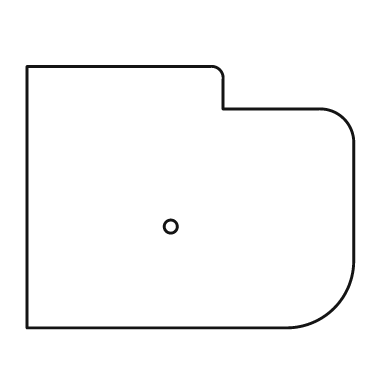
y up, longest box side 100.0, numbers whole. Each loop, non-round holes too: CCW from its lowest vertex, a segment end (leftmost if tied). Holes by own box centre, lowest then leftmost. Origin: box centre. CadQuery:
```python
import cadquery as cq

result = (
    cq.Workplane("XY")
    .moveTo(-50.0, -40.0)
    .lineTo(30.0, -40.0)
    .threePointArc((44.0, -34.0), (50.0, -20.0))
    .lineTo(50.0, 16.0)
    .threePointArc((47.0, 24.0), (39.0, 27.0))
    .lineTo(10.0, 27.0)
    .lineTo(10.0, 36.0)
    .threePointArc((9.0, 39.0), (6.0, 40.0))
    .lineTo(-50.0, 40.0)
    .close()
    .moveTo(-6.0, -9.0)
    .circle(2.0)
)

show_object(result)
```